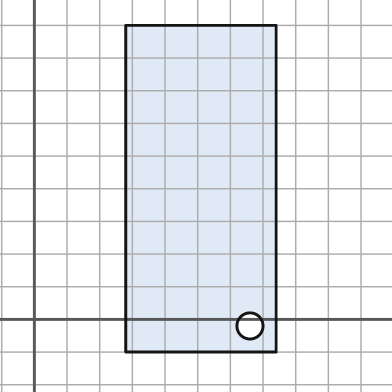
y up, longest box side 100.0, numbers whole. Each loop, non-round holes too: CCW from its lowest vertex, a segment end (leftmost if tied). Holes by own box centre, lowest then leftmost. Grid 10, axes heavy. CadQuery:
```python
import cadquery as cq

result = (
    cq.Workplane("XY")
    .moveTo(28.0, -10.0)
    .lineTo(74.0, -10.0)
    .lineTo(74.0, 90.0)
    .lineTo(28.0, 90.0)
    .close()
    .moveTo(66.0, -2.0)
    .circle(4.0)
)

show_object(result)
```